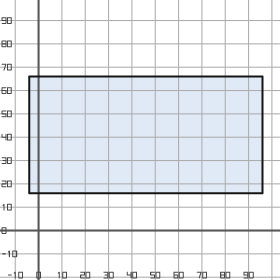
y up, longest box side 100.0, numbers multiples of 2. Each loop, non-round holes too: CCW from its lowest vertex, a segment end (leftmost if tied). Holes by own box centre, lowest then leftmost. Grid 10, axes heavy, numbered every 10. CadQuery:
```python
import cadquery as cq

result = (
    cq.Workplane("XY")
    .moveTo(-4.0, 16.0)
    .lineTo(96.0, 16.0)
    .lineTo(96.0, 66.0)
    .lineTo(-4.0, 66.0)
    .close()
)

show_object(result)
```